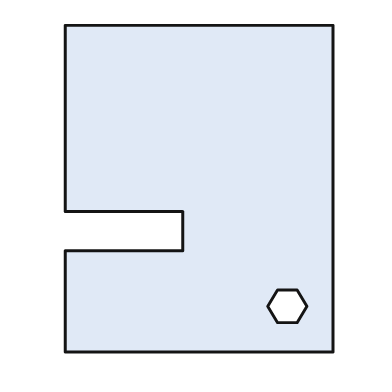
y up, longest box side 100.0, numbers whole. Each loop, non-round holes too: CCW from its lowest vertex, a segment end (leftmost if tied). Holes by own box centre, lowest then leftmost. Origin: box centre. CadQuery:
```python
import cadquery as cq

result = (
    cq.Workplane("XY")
    .moveTo(-41.0, -50.0)
    .lineTo(41.0, -50.0)
    .lineTo(41.0, 50.0)
    .lineTo(-41.0, 50.0)
    .lineTo(-41.0, -7.0)
    .lineTo(-5.0, -7.0)
    .lineTo(-5.0, -19.0)
    .lineTo(-41.0, -19.0)
    .close()
    .moveTo(24.0, -41.0)
    .lineTo(30.0, -41.0)
    .lineTo(33.0, -36.0)
    .lineTo(30.0, -31.0)
    .lineTo(24.0, -31.0)
    .lineTo(21.0, -36.0)
    .close()
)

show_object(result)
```